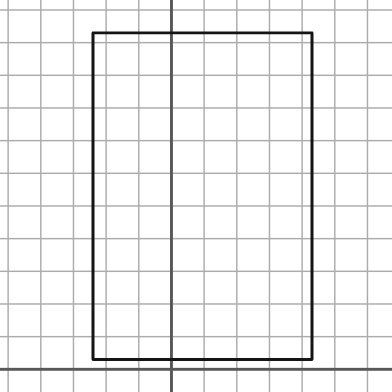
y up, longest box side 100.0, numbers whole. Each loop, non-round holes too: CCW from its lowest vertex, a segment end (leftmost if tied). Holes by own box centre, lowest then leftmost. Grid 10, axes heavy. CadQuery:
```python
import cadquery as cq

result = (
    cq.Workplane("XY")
    .moveTo(-24.0, 3.0)
    .lineTo(43.0, 3.0)
    .lineTo(43.0, 103.0)
    .lineTo(-24.0, 103.0)
    .close()
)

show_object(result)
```